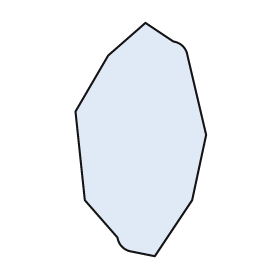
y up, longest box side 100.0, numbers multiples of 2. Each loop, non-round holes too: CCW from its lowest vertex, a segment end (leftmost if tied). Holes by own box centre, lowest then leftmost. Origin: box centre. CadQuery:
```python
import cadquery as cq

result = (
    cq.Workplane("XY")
    .moveTo(6.0, -50.0)
    .lineTo(22.0, -26.0)
    .lineTo(28.0, 2.0)
    .lineTo(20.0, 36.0)
    .threePointArc((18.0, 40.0), (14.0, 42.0))
    .lineTo(2.0, 50.0)
    .lineTo(-14.0, 36.0)
    .lineTo(-28.0, 12.0)
    .lineTo(-24.0, -26.0)
    .lineTo(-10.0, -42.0)
    .threePointArc((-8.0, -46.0), (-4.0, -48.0))
    .close()
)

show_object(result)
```